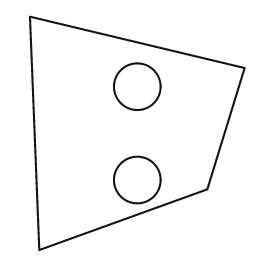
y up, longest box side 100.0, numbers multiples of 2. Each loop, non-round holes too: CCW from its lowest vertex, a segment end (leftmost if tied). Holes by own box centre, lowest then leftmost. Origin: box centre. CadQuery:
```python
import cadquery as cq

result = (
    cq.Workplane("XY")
    .moveTo(-42.0, -50.0)
    .lineTo(30.0, -24.0)
    .lineTo(46.0, 28.0)
    .lineTo(-46.0, 50.0)
    .close()
    .moveTo(0.0, -20.0)
    .circle(10.0)
    .moveTo(0.0, 20.0)
    .circle(10.0)
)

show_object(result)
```